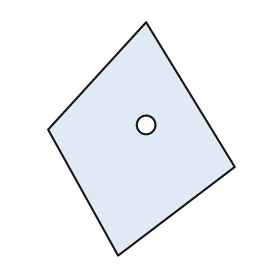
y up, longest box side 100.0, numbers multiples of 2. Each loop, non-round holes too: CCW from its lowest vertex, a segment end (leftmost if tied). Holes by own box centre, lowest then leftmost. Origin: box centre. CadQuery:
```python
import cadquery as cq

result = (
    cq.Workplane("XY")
    .moveTo(-10.0, -50.0)
    .lineTo(40.0, -12.0)
    .lineTo(2.0, 50.0)
    .lineTo(-40.0, 4.0)
    .close()
    .moveTo(2.0, 6.0)
    .circle(4.0)
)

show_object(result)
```